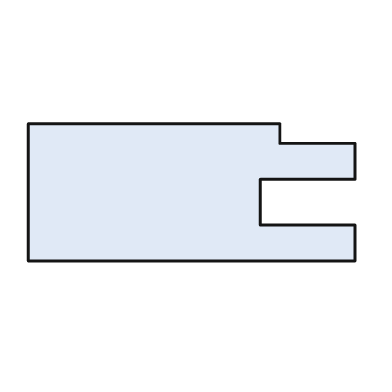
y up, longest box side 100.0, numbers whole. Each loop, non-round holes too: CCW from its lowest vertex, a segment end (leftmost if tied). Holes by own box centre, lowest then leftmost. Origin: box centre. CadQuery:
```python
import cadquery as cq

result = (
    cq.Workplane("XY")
    .moveTo(-50.0, -21.0)
    .lineTo(50.0, -21.0)
    .lineTo(50.0, -10.0)
    .lineTo(21.0, -10.0)
    .lineTo(21.0, 4.0)
    .lineTo(50.0, 4.0)
    .lineTo(50.0, 15.0)
    .lineTo(27.0, 15.0)
    .lineTo(27.0, 21.0)
    .lineTo(-50.0, 21.0)
    .close()
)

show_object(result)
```